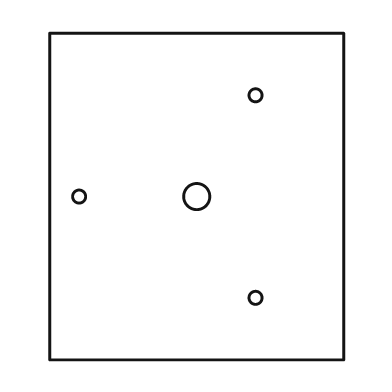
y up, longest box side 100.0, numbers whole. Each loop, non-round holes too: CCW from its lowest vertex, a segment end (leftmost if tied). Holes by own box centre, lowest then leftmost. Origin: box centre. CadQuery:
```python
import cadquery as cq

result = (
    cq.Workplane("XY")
    .moveTo(-45.0, -50.0)
    .lineTo(45.0, -50.0)
    .lineTo(45.0, 50.0)
    .lineTo(-45.0, 50.0)
    .close()
    .moveTo(18.0, -31.0)
    .circle(2.0)
    .moveTo(-36.0, 0.0)
    .circle(2.0)
    .moveTo(0.0, 0.0)
    .circle(4.0)
    .moveTo(18.0, 31.0)
    .circle(2.0)
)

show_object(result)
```